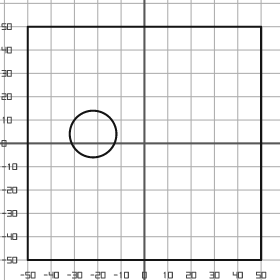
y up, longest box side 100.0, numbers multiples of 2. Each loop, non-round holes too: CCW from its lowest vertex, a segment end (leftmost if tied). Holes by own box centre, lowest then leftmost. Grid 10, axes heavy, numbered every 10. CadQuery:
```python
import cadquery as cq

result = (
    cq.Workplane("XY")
    .moveTo(-50.0, -50.0)
    .lineTo(50.0, -50.0)
    .lineTo(50.0, 50.0)
    .lineTo(-50.0, 50.0)
    .close()
    .moveTo(-22.0, 4.0)
    .circle(10.0)
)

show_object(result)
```